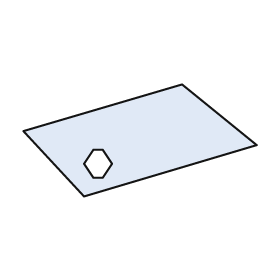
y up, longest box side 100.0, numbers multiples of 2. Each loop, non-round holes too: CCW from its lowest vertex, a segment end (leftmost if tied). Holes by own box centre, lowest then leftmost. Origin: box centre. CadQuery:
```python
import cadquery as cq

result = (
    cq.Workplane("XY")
    .moveTo(-24.0, -24.0)
    .lineTo(50.0, -2.0)
    .lineTo(18.0, 24.0)
    .lineTo(-50.0, 4.0)
    .close()
    .moveTo(-20.0, -16.0)
    .lineTo(-16.0, -16.0)
    .lineTo(-12.0, -10.0)
    .lineTo(-16.0, -4.0)
    .lineTo(-20.0, -4.0)
    .lineTo(-24.0, -10.0)
    .close()
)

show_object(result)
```